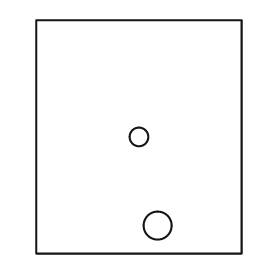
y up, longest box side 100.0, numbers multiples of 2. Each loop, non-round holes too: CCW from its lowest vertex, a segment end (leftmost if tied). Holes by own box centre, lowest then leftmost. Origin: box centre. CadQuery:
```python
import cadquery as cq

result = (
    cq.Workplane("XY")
    .moveTo(-44.0, -50.0)
    .lineTo(44.0, -50.0)
    .lineTo(44.0, 50.0)
    .lineTo(-44.0, 50.0)
    .close()
    .moveTo(8.0, -38.0)
    .circle(6.0)
    .moveTo(0.0, 0.0)
    .circle(4.0)
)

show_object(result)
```